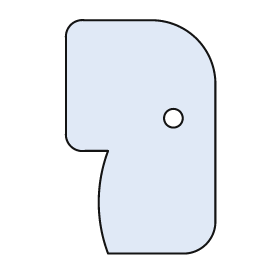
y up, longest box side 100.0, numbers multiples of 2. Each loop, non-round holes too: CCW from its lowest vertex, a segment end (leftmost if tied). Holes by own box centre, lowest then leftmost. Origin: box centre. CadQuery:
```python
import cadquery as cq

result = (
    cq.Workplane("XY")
    .moveTo(-14.0, -50.0)
    .lineTo(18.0, -50.0)
    .threePointArc((28.0, -46.0), (32.0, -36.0))
    .lineTo(32.0, 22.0)
    .threePointArc((24.0, 42.0), (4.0, 50.0))
    .lineTo(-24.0, 50.0)
    .threePointArc((-30.0, 48.0), (-32.0, 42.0))
    .lineTo(-32.0, 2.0)
    .threePointArc((-30.0, -4.0), (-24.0, -6.0))
    .lineTo(-14.0, -6.0)
    .threePointArc((-18.0, -28.0), (-14.0, -50.0))
    .close()
    .moveTo(14.0, 8.0)
    .circle(4.0)
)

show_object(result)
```